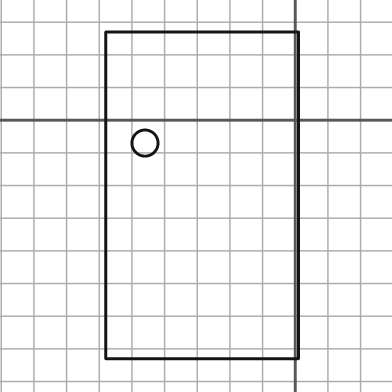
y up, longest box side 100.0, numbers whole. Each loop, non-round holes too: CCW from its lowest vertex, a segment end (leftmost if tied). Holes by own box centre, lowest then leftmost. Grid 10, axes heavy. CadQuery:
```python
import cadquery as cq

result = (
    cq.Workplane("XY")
    .moveTo(-58.0, -73.0)
    .lineTo(1.0, -73.0)
    .lineTo(1.0, 27.0)
    .lineTo(-58.0, 27.0)
    .close()
    .moveTo(-46.0, -7.0)
    .circle(4.0)
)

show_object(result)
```